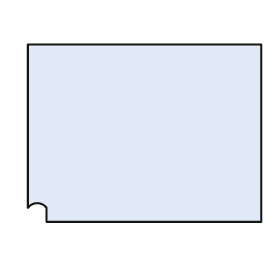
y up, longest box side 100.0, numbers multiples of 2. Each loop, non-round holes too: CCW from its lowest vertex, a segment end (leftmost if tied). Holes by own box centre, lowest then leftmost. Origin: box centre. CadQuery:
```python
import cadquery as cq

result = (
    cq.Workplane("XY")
    .moveTo(-42.0, -38.0)
    .lineTo(50.0, -38.0)
    .lineTo(50.0, 38.0)
    .lineTo(-50.0, 38.0)
    .lineTo(-50.0, -32.0)
    .threePointArc((-46.0, -30.0), (-42.0, -32.0))
    .close()
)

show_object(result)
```